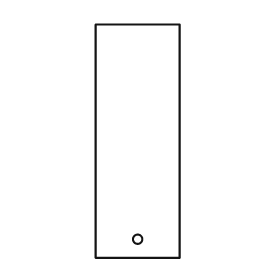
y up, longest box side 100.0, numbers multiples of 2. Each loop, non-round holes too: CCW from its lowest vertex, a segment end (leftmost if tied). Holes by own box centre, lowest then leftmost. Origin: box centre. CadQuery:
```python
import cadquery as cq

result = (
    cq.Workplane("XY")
    .moveTo(-18.0, -50.0)
    .lineTo(18.0, -50.0)
    .lineTo(18.0, 50.0)
    .lineTo(-18.0, 50.0)
    .close()
    .moveTo(0.0, -42.0)
    .circle(2.0)
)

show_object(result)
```